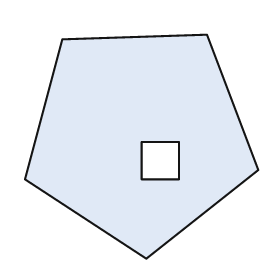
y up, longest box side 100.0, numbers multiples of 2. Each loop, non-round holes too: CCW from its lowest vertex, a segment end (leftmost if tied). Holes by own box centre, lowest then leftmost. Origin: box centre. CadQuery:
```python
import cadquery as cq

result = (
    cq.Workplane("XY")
    .moveTo(2.0, -48.0)
    .lineTo(50.0, -10.0)
    .lineTo(28.0, 48.0)
    .lineTo(-34.0, 46.0)
    .lineTo(-50.0, -14.0)
    .close()
    .moveTo(0.0, -14.0)
    .lineTo(16.0, -14.0)
    .lineTo(16.0, 2.0)
    .lineTo(0.0, 2.0)
    .close()
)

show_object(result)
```